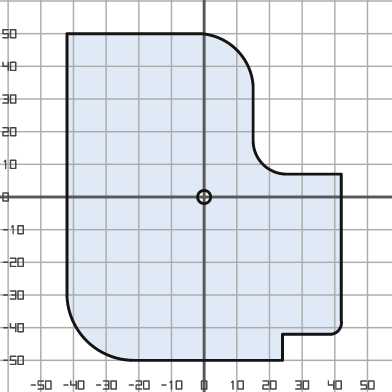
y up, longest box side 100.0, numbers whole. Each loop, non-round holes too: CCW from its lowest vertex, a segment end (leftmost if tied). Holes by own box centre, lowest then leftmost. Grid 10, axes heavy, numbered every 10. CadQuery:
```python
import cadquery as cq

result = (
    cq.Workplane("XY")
    .moveTo(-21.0, -50.0)
    .lineTo(24.0, -50.0)
    .lineTo(24.0, -42.0)
    .lineTo(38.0, -42.0)
    .threePointArc((41.0, -41.0), (42.0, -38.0))
    .lineTo(42.0, 7.0)
    .lineTo(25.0, 7.0)
    .threePointArc((18.0, 10.0), (15.0, 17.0))
    .lineTo(15.0, 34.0)
    .threePointArc((10.0, 45.0), (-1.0, 50.0))
    .lineTo(-42.0, 50.0)
    .lineTo(-42.0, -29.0)
    .threePointArc((-36.0, -44.0), (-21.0, -50.0))
    .close()
    .moveTo(0.0, 0.0)
    .circle(2.0)
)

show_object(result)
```